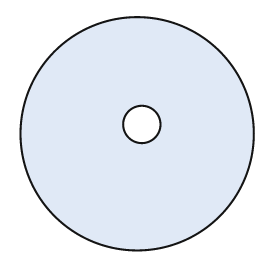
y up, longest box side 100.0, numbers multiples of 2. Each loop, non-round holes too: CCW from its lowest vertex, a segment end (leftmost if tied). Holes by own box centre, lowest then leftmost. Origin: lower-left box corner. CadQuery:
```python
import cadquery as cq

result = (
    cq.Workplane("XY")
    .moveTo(50.0, 50.0)
    .circle(50.0)
    .moveTo(52.0, 54.0)
    .circle(8.0)
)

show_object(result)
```